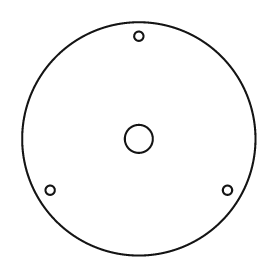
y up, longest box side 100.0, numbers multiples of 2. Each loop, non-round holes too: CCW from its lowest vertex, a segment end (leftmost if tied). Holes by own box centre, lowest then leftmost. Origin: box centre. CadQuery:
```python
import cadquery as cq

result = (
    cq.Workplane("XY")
    .moveTo(0.0, 0.0)
    .circle(50.0)
    .moveTo(-38.0, -22.0)
    .circle(2.0)
    .moveTo(38.0, -22.0)
    .circle(2.0)
    .moveTo(0.0, 0.0)
    .circle(6.0)
    .moveTo(0.0, 44.0)
    .circle(2.0)
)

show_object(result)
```